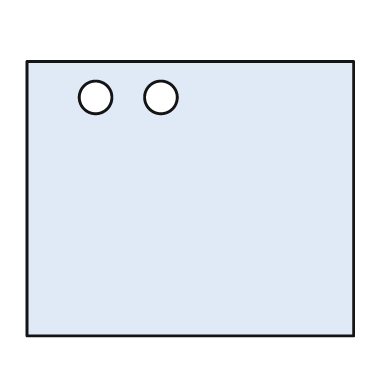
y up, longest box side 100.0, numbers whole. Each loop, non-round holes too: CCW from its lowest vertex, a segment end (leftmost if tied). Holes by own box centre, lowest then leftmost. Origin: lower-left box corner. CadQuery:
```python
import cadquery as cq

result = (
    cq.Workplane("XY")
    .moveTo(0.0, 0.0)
    .lineTo(100.0, 0.0)
    .lineTo(100.0, 84.0)
    .lineTo(0.0, 84.0)
    .close()
    .moveTo(21.0, 73.0)
    .circle(5.0)
    .moveTo(41.0, 73.0)
    .circle(5.0)
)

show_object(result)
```